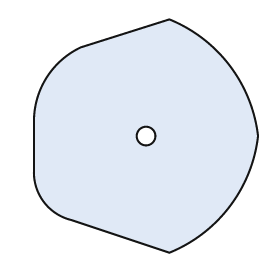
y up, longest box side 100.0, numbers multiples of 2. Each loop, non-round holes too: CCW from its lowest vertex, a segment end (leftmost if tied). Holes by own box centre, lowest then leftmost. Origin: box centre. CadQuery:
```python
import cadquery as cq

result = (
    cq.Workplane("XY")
    .moveTo(10.0, -50.0)
    .threePointArc((36.0, -30.0), (48.0, 0.0))
    .threePointArc((36.0, 30.0), (10.0, 50.0))
    .lineTo(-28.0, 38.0)
    .threePointArc((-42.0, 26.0), (-48.0, 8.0))
    .lineTo(-48.0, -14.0)
    .threePointArc((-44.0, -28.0), (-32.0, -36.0))
    .close()
    .moveTo(0.0, 0.0)
    .circle(4.0)
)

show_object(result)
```